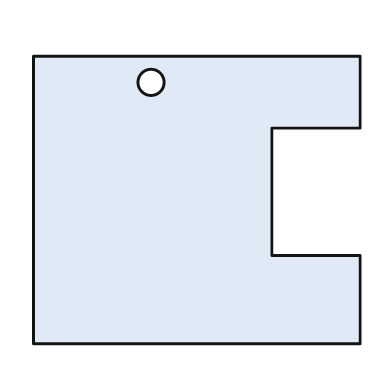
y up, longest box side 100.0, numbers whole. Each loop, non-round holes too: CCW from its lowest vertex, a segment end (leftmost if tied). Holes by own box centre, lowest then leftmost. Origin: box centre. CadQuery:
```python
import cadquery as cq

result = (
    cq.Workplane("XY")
    .moveTo(-50.0, -44.0)
    .lineTo(50.0, -44.0)
    .lineTo(50.0, -17.0)
    .lineTo(23.0, -17.0)
    .lineTo(23.0, 22.0)
    .lineTo(50.0, 22.0)
    .lineTo(50.0, 44.0)
    .lineTo(-50.0, 44.0)
    .close()
    .moveTo(-14.0, 36.0)
    .circle(4.0)
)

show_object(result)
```